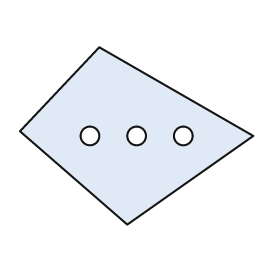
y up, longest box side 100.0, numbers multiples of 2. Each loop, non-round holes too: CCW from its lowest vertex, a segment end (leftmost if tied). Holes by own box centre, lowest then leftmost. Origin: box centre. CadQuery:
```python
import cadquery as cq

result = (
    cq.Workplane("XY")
    .moveTo(-4.0, -38.0)
    .lineTo(50.0, 0.0)
    .lineTo(-16.0, 38.0)
    .lineTo(-50.0, 2.0)
    .close()
    .moveTo(-20.0, 0.0)
    .circle(4.0)
    .moveTo(0.0, 0.0)
    .circle(4.0)
    .moveTo(20.0, 0.0)
    .circle(4.0)
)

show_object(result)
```